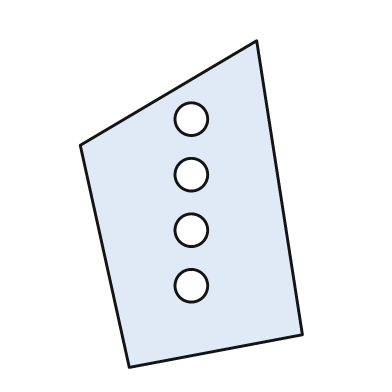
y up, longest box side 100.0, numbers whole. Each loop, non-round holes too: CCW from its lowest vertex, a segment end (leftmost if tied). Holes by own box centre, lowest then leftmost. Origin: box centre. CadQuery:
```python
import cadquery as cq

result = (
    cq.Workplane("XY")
    .moveTo(-19.0, -50.0)
    .lineTo(34.0, -40.0)
    .lineTo(20.0, 50.0)
    .lineTo(-34.0, 18.0)
    .close()
    .moveTo(0.0, -25.0)
    .circle(5.0)
    .moveTo(0.0, -8.0)
    .circle(5.0)
    .moveTo(0.0, 9.0)
    .circle(5.0)
    .moveTo(0.0, 26.0)
    .circle(5.0)
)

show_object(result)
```